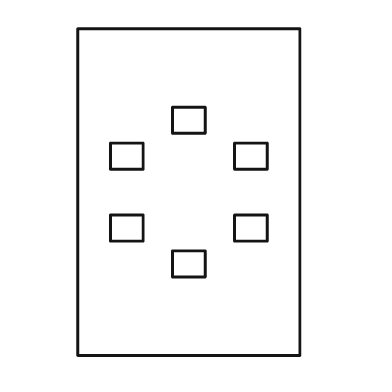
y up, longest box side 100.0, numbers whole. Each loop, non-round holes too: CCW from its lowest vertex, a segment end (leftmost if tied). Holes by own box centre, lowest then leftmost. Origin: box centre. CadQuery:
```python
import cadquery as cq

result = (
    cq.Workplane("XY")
    .moveTo(-34.0, -50.0)
    .lineTo(34.0, -50.0)
    .lineTo(34.0, 50.0)
    .lineTo(-34.0, 50.0)
    .close()
    .moveTo(-5.0, -26.0)
    .lineTo(5.0, -26.0)
    .lineTo(5.0, -18.0)
    .lineTo(-5.0, -18.0)
    .close()
    .moveTo(-24.0, -15.0)
    .lineTo(-14.0, -15.0)
    .lineTo(-14.0, -7.0)
    .lineTo(-24.0, -7.0)
    .close()
    .moveTo(14.0, -15.0)
    .lineTo(24.0, -15.0)
    .lineTo(24.0, -7.0)
    .lineTo(14.0, -7.0)
    .close()
    .moveTo(-24.0, 7.0)
    .lineTo(-14.0, 7.0)
    .lineTo(-14.0, 15.0)
    .lineTo(-24.0, 15.0)
    .close()
    .moveTo(14.0, 7.0)
    .lineTo(24.0, 7.0)
    .lineTo(24.0, 15.0)
    .lineTo(14.0, 15.0)
    .close()
    .moveTo(-5.0, 18.0)
    .lineTo(5.0, 18.0)
    .lineTo(5.0, 26.0)
    .lineTo(-5.0, 26.0)
    .close()
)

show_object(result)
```